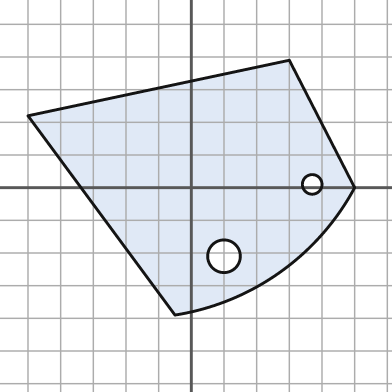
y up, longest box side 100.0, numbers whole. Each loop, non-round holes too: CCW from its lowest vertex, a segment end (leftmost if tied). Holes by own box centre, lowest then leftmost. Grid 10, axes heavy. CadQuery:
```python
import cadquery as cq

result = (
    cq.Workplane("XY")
    .moveTo(-5.0, -39.0)
    .threePointArc((27.0, -26.0), (50.0, 0.0))
    .lineTo(30.0, 39.0)
    .lineTo(-50.0, 22.0)
    .close()
    .moveTo(10.0, -21.0)
    .circle(5.0)
    .moveTo(37.0, 1.0)
    .circle(3.0)
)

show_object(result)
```